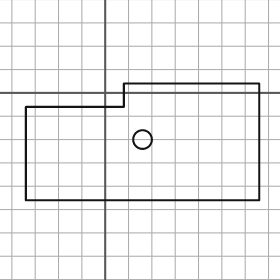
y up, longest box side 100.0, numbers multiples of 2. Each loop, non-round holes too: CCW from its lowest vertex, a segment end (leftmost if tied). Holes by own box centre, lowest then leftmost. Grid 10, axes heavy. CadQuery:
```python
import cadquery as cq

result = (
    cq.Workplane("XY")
    .moveTo(-34.0, -46.0)
    .lineTo(66.0, -46.0)
    .lineTo(66.0, 4.0)
    .lineTo(8.0, 4.0)
    .lineTo(8.0, -6.0)
    .lineTo(-34.0, -6.0)
    .close()
    .moveTo(16.0, -20.0)
    .circle(4.0)
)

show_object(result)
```